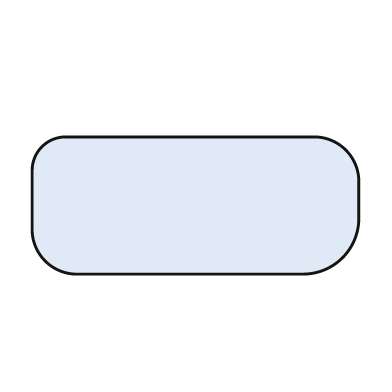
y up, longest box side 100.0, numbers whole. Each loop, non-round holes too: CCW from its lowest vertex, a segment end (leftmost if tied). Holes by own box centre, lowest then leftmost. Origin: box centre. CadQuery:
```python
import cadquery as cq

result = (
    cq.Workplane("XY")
    .moveTo(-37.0, -21.0)
    .lineTo(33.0, -21.0)
    .threePointArc((45.0, -16.0), (50.0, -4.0))
    .lineTo(50.0, 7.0)
    .threePointArc((46.0, 17.0), (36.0, 21.0))
    .lineTo(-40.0, 21.0)
    .threePointArc((-47.0, 18.0), (-50.0, 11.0))
    .lineTo(-50.0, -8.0)
    .threePointArc((-46.0, -17.0), (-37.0, -21.0))
    .close()
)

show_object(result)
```